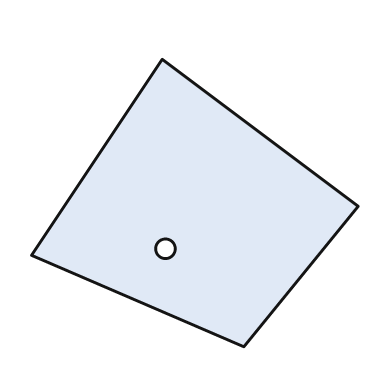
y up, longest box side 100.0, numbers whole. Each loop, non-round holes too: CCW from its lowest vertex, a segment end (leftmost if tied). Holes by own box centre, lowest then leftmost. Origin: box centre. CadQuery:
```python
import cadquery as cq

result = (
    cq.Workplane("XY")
    .moveTo(15.0, -44.0)
    .lineTo(50.0, -1.0)
    .lineTo(-10.0, 44.0)
    .lineTo(-50.0, -16.0)
    .close()
    .moveTo(-9.0, -14.0)
    .circle(3.0)
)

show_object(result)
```